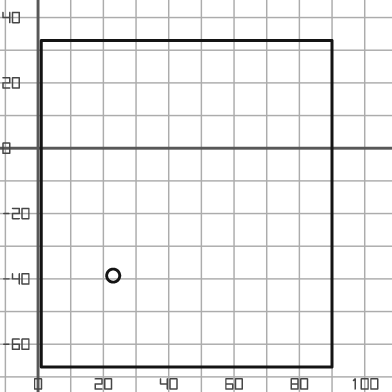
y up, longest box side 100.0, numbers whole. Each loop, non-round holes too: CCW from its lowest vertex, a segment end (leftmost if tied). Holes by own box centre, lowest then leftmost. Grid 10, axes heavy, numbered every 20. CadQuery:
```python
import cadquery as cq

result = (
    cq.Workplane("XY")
    .moveTo(1.0, -67.0)
    .lineTo(90.0, -67.0)
    .lineTo(90.0, 33.0)
    .lineTo(1.0, 33.0)
    .close()
    .moveTo(23.0, -39.0)
    .circle(2.0)
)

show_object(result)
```